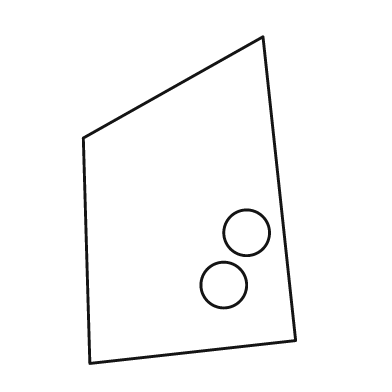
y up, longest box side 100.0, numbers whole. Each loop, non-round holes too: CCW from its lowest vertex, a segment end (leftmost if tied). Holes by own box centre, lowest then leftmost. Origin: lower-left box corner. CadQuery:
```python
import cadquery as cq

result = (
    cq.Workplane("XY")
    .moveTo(2.0, 0.0)
    .lineTo(65.0, 7.0)
    .lineTo(55.0, 100.0)
    .lineTo(0.0, 69.0)
    .close()
    .moveTo(43.0, 24.0)
    .circle(7.0)
    .moveTo(50.0, 40.0)
    .circle(7.0)
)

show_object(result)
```